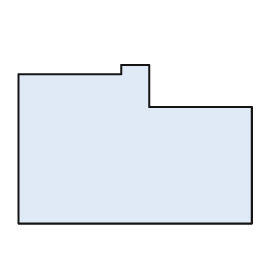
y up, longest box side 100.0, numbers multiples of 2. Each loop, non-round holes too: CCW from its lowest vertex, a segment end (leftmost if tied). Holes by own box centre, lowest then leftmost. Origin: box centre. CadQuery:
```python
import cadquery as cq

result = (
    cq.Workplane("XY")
    .moveTo(-50.0, -34.0)
    .lineTo(50.0, -34.0)
    .lineTo(50.0, 16.0)
    .lineTo(6.0, 16.0)
    .lineTo(6.0, 34.0)
    .lineTo(-6.0, 34.0)
    .lineTo(-6.0, 30.0)
    .lineTo(-50.0, 30.0)
    .close()
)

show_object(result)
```